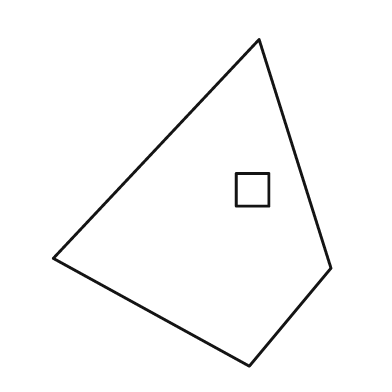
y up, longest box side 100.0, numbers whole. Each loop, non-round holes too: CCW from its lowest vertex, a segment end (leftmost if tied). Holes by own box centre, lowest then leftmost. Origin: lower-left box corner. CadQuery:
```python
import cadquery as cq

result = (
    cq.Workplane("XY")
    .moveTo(60.0, 0.0)
    .lineTo(85.0, 30.0)
    .lineTo(63.0, 100.0)
    .lineTo(0.0, 33.0)
    .close()
    .moveTo(56.0, 49.0)
    .lineTo(66.0, 49.0)
    .lineTo(66.0, 59.0)
    .lineTo(56.0, 59.0)
    .close()
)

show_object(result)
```